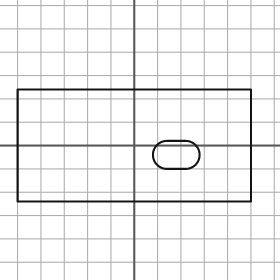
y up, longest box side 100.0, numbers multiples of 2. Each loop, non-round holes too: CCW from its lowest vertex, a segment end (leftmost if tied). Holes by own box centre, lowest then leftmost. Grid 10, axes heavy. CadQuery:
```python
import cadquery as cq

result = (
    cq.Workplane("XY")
    .moveTo(-50.0, -24.0)
    .lineTo(50.0, -24.0)
    .lineTo(50.0, 24.0)
    .lineTo(-50.0, 24.0)
    .close()
    .moveTo(14.0, -10.0)
    .lineTo(22.0, -10.0)
    .threePointArc((28.0, -4.0), (22.0, 2.0))
    .lineTo(14.0, 2.0)
    .threePointArc((8.0, -4.0), (14.0, -10.0))
    .close()
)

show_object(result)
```